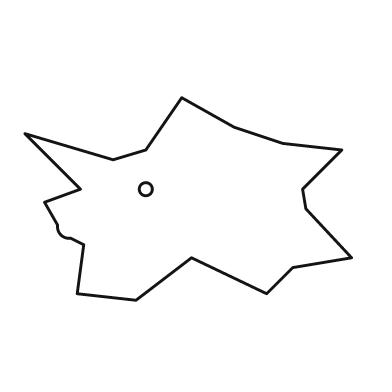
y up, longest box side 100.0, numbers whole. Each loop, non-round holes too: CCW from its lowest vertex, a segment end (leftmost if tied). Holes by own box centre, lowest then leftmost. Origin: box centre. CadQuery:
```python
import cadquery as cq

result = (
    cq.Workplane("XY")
    .moveTo(-16.0, -31.0)
    .lineTo(1.0, -18.0)
    .lineTo(24.0, -29.0)
    .lineTo(32.0, -21.0)
    .lineTo(50.0, -18.0)
    .lineTo(36.0, -3.0)
    .lineTo(35.0, 3.0)
    .lineTo(47.0, 15.0)
    .lineTo(29.0, 17.0)
    .lineTo(14.0, 22.0)
    .lineTo(-2.0, 31.0)
    .lineTo(-13.0, 15.0)
    .lineTo(-23.0, 12.0)
    .lineTo(-50.0, 20.0)
    .lineTo(-33.0, 3.0)
    .lineTo(-44.0, -1.0)
    .lineTo(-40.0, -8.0)
    .threePointArc((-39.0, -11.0), (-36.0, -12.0))
    .lineTo(-32.0, -14.0)
    .lineTo(-34.0, -29.0)
    .close()
    .moveTo(-13.0, 3.0)
    .circle(2.0)
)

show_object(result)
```